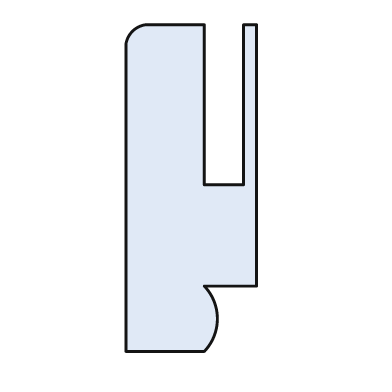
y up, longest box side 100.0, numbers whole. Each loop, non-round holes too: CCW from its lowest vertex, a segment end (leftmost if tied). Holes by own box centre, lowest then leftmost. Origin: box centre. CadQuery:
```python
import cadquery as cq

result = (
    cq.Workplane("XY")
    .moveTo(-20.0, -50.0)
    .lineTo(4.0, -50.0)
    .threePointArc((8.0, -40.0), (4.0, -30.0))
    .lineTo(20.0, -30.0)
    .lineTo(20.0, 50.0)
    .lineTo(16.0, 50.0)
    .lineTo(16.0, 1.0)
    .lineTo(4.0, 1.0)
    .lineTo(4.0, 50.0)
    .lineTo(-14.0, 50.0)
    .threePointArc((-18.0, 48.0), (-20.0, 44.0))
    .close()
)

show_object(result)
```